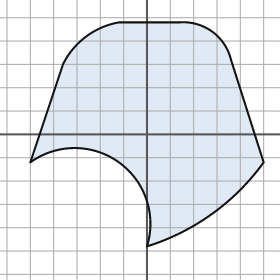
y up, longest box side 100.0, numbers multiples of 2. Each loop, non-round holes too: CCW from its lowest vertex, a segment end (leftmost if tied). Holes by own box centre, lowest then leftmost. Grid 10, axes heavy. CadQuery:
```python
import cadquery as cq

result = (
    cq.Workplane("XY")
    .moveTo(0.0, -48.0)
    .threePointArc((28.0, -34.0), (50.0, -12.0))
    .lineTo(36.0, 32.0)
    .threePointArc((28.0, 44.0), (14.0, 48.0))
    .lineTo(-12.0, 48.0)
    .threePointArc((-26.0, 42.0), (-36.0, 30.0))
    .lineTo(-50.0, -12.0)
    .threePointArc((-12.0, -12.0), (0.0, -48.0))
    .close()
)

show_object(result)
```